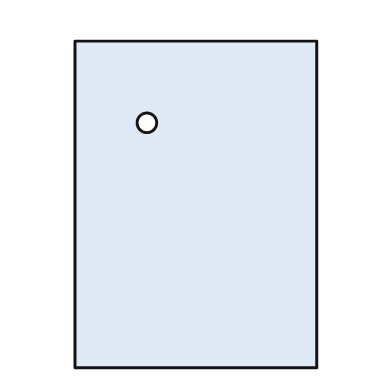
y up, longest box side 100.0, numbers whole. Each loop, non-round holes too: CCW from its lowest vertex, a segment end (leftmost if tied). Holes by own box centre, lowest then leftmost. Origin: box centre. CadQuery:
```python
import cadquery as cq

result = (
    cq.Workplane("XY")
    .moveTo(-37.0, -50.0)
    .lineTo(37.0, -50.0)
    .lineTo(37.0, 50.0)
    .lineTo(-37.0, 50.0)
    .close()
    .moveTo(-15.0, 25.0)
    .circle(3.0)
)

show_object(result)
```